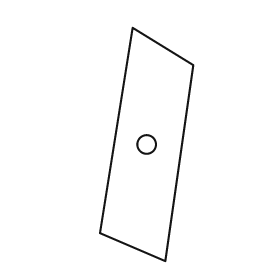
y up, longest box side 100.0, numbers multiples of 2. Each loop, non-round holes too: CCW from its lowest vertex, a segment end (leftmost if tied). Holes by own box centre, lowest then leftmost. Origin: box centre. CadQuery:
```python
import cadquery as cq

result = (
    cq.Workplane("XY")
    .moveTo(8.0, -50.0)
    .lineTo(20.0, 34.0)
    .lineTo(-6.0, 50.0)
    .lineTo(-20.0, -38.0)
    .close()
    .moveTo(0.0, 0.0)
    .circle(4.0)
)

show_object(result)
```